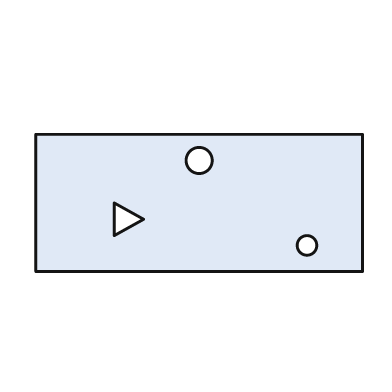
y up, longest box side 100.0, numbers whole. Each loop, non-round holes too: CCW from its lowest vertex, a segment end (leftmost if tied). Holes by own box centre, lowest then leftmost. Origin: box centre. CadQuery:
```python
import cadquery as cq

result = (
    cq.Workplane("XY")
    .moveTo(-50.0, -21.0)
    .lineTo(50.0, -21.0)
    .lineTo(50.0, 21.0)
    .lineTo(-50.0, 21.0)
    .close()
    .moveTo(33.0, -13.0)
    .circle(3.0)
    .moveTo(-26.0, -10.0)
    .lineTo(-17.0, -5.0)
    .lineTo(-26.0, 0.0)
    .close()
    .moveTo(0.0, 13.0)
    .circle(4.0)
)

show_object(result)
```